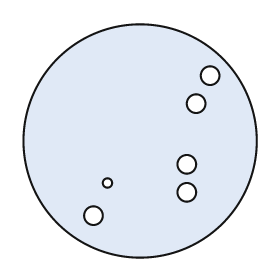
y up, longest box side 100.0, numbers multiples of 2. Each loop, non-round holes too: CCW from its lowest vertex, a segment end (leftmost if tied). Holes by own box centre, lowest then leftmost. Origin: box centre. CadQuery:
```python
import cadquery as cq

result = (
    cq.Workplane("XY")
    .moveTo(0.0, 0.0)
    .circle(50.0)
    .moveTo(-20.0, -32.0)
    .circle(4.0)
    .moveTo(20.0, -22.0)
    .circle(4.0)
    .moveTo(-14.0, -18.0)
    .circle(2.0)
    .moveTo(20.0, -10.0)
    .circle(4.0)
    .moveTo(24.0, 16.0)
    .circle(4.0)
    .moveTo(30.0, 28.0)
    .circle(4.0)
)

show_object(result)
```